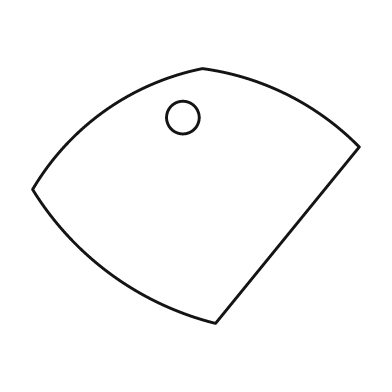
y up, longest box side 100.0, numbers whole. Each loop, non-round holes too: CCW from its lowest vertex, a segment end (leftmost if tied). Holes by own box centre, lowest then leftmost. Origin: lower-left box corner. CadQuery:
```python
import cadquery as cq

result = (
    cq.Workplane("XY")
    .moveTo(56.0, 0.0)
    .lineTo(100.0, 54.0)
    .threePointArc((78.0, 70.0), (52.0, 78.0))
    .threePointArc((22.0, 65.0), (0.0, 41.0))
    .threePointArc((24.0, 15.0), (56.0, 0.0))
    .close()
    .moveTo(46.0, 63.0)
    .circle(5.0)
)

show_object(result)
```